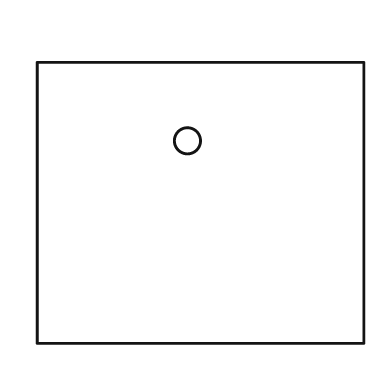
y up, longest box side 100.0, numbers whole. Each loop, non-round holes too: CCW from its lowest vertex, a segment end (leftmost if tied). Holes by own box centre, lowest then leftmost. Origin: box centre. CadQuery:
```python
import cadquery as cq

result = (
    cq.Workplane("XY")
    .moveTo(-50.0, -43.0)
    .lineTo(50.0, -43.0)
    .lineTo(50.0, 43.0)
    .lineTo(-50.0, 43.0)
    .close()
    .moveTo(-4.0, 19.0)
    .circle(4.0)
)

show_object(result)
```